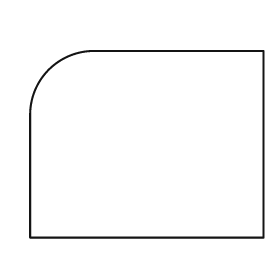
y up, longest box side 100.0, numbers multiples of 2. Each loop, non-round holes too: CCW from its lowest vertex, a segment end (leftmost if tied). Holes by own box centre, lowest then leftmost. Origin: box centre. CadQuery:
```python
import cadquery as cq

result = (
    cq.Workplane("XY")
    .moveTo(-50.0, -40.0)
    .lineTo(50.0, -40.0)
    .lineTo(50.0, 40.0)
    .lineTo(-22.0, 40.0)
    .threePointArc((-42.0, 32.0), (-50.0, 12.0))
    .close()
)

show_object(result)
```